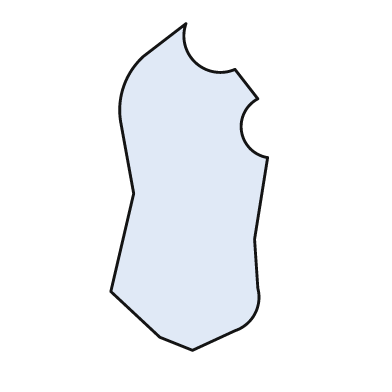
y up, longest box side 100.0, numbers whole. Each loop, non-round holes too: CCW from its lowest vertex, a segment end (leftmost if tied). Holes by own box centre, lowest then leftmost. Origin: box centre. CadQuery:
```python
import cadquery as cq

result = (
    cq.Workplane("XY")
    .moveTo(1.0, -50.0)
    .lineTo(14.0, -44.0)
    .threePointArc((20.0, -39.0), (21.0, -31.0))
    .lineTo(20.0, -16.0)
    .lineTo(24.0, 9.0)
    .threePointArc((16.0, 17.0), (21.0, 27.0))
    .lineTo(14.0, 36.0)
    .threePointArc((2.0, 38.0), (-1.0, 50.0))
    .lineTo(-14.0, 40.0)
    .threePointArc((-20.0, 31.0), (-21.0, 20.0))
    .lineTo(-17.0, -2.0)
    .lineTo(-24.0, -32.0)
    .lineTo(-9.0, -46.0)
    .close()
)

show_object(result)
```